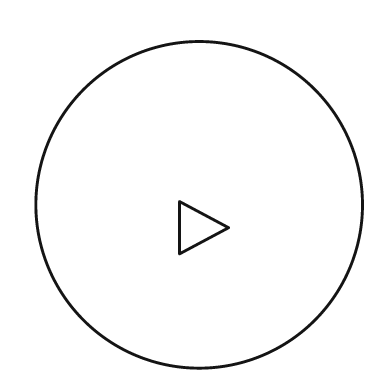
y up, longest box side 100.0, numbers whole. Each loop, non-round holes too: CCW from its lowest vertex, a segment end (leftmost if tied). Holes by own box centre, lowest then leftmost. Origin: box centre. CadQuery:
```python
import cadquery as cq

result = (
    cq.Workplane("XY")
    .moveTo(0.0, 0.0)
    .circle(50.0)
    .moveTo(-6.0, -15.0)
    .lineTo(9.0, -7.0)
    .lineTo(-6.0, 1.0)
    .close()
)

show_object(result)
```